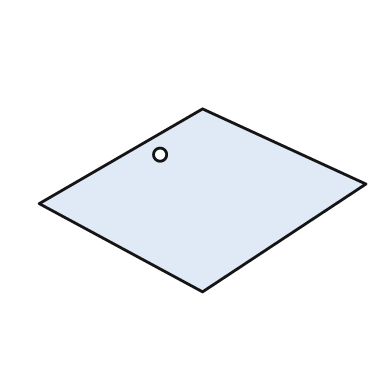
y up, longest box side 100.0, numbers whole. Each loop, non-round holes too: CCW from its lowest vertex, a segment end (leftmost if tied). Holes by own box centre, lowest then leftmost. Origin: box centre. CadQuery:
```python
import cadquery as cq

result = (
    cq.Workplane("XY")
    .moveTo(0.0, -28.0)
    .lineTo(50.0, 5.0)
    .lineTo(0.0, 28.0)
    .lineTo(-50.0, -1.0)
    .close()
    .moveTo(-13.0, 14.0)
    .circle(2.0)
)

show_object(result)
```